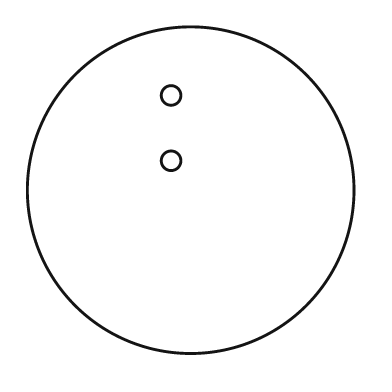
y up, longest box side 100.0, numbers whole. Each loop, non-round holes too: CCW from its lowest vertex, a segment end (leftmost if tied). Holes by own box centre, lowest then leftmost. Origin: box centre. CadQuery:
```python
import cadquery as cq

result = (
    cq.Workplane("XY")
    .moveTo(0.0, 0.0)
    .circle(50.0)
    .moveTo(-6.0, 9.0)
    .circle(3.0)
    .moveTo(-6.0, 29.0)
    .circle(3.0)
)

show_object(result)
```